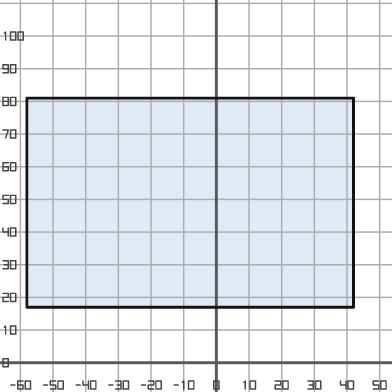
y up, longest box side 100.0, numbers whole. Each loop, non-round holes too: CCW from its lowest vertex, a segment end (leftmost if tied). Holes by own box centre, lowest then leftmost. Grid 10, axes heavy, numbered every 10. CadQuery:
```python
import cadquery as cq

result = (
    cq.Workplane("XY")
    .moveTo(-58.0, 17.0)
    .lineTo(42.0, 17.0)
    .lineTo(42.0, 81.0)
    .lineTo(-58.0, 81.0)
    .close()
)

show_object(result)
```